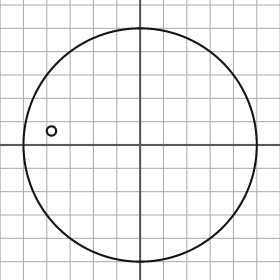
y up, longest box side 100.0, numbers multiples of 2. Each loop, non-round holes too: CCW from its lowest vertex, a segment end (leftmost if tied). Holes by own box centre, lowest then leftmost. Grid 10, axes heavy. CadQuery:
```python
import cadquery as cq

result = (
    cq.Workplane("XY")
    .moveTo(0.0, 0.0)
    .circle(50.0)
    .moveTo(-38.0, 6.0)
    .circle(2.0)
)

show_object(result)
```